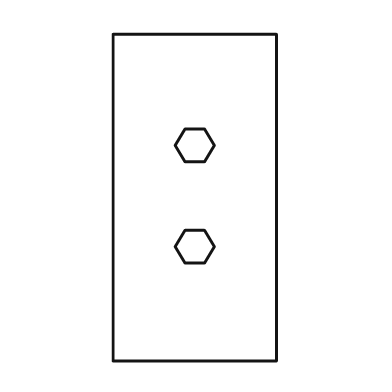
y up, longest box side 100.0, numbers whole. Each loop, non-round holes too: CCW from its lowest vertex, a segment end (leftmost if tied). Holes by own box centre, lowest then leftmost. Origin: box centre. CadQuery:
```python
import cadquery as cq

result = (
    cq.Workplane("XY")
    .moveTo(-25.0, -50.0)
    .lineTo(25.0, -50.0)
    .lineTo(25.0, 50.0)
    .lineTo(-25.0, 50.0)
    .close()
    .moveTo(-3.0, -20.0)
    .lineTo(3.0, -20.0)
    .lineTo(6.0, -15.0)
    .lineTo(3.0, -10.0)
    .lineTo(-3.0, -10.0)
    .lineTo(-6.0, -15.0)
    .close()
    .moveTo(-3.0, 11.0)
    .lineTo(3.0, 11.0)
    .lineTo(6.0, 16.0)
    .lineTo(3.0, 21.0)
    .lineTo(-3.0, 21.0)
    .lineTo(-6.0, 16.0)
    .close()
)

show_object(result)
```